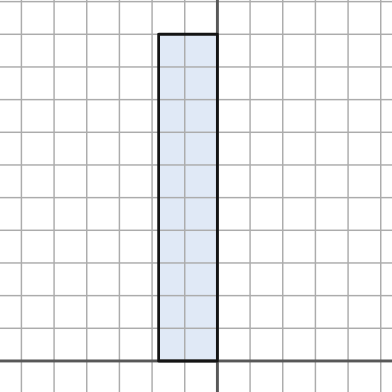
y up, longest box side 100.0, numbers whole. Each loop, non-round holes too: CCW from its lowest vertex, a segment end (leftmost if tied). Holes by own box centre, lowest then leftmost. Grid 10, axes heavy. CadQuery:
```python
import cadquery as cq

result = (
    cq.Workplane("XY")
    .moveTo(-18.0, 0.0)
    .lineTo(0.0, 0.0)
    .lineTo(0.0, 100.0)
    .lineTo(-18.0, 100.0)
    .close()
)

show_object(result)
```